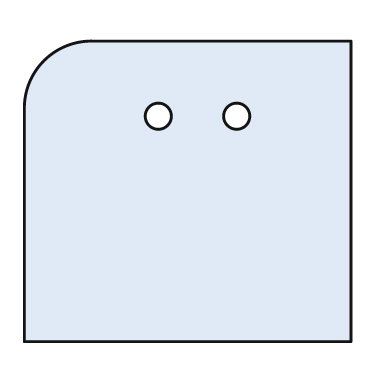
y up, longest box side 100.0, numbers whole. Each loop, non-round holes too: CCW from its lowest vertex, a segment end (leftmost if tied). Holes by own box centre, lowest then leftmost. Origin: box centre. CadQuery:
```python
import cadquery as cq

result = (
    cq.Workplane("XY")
    .moveTo(-50.0, -46.0)
    .lineTo(50.0, -46.0)
    .lineTo(50.0, 46.0)
    .lineTo(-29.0, 46.0)
    .threePointArc((-44.0, 40.0), (-50.0, 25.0))
    .close()
    .moveTo(-9.0, 23.0)
    .circle(4.0)
    .moveTo(15.0, 23.0)
    .circle(4.0)
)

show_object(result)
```